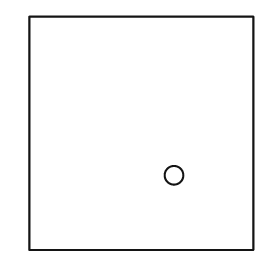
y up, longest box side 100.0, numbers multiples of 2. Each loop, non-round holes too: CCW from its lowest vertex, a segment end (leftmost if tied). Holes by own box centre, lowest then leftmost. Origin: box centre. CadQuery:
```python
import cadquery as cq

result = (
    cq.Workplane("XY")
    .moveTo(-48.0, -50.0)
    .lineTo(48.0, -50.0)
    .lineTo(48.0, 50.0)
    .lineTo(-48.0, 50.0)
    .close()
    .moveTo(14.0, -18.0)
    .circle(4.0)
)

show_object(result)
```